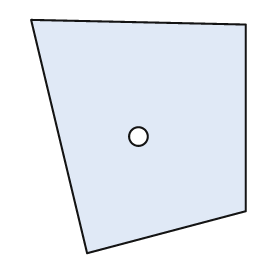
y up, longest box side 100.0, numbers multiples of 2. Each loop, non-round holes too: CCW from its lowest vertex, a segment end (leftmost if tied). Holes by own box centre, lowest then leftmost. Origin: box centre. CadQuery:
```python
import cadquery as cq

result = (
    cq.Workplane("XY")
    .moveTo(-22.0, -50.0)
    .lineTo(46.0, -32.0)
    .lineTo(46.0, 48.0)
    .lineTo(-46.0, 50.0)
    .close()
    .moveTo(0.0, 0.0)
    .circle(4.0)
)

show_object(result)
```